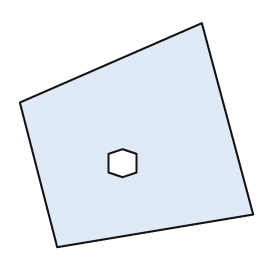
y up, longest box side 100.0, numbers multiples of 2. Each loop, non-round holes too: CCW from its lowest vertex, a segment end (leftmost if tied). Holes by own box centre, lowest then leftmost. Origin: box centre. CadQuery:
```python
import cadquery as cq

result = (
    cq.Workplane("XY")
    .moveTo(-34.0, -48.0)
    .lineTo(50.0, -34.0)
    .lineTo(28.0, 48.0)
    .lineTo(-50.0, 14.0)
    .close()
    .moveTo(-6.0, -18.0)
    .lineTo(0.0, -16.0)
    .lineTo(0.0, -8.0)
    .lineTo(-6.0, -6.0)
    .lineTo(-12.0, -8.0)
    .lineTo(-12.0, -16.0)
    .close()
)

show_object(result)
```